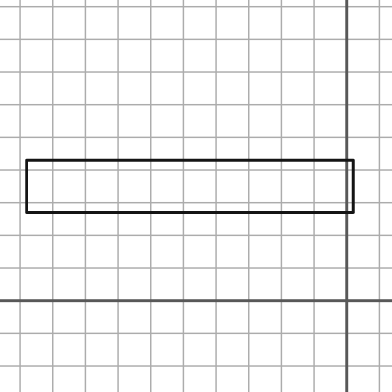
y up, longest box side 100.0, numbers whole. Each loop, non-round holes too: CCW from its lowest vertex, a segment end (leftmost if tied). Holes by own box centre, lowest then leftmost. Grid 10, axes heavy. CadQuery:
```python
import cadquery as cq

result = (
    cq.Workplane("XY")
    .moveTo(-98.0, 27.0)
    .lineTo(2.0, 27.0)
    .lineTo(2.0, 43.0)
    .lineTo(-98.0, 43.0)
    .close()
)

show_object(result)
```